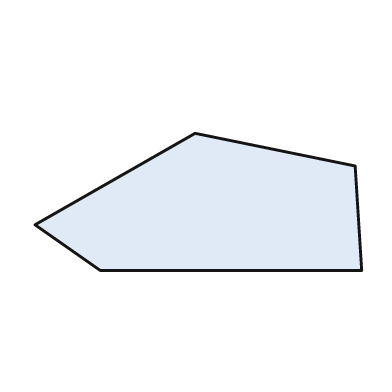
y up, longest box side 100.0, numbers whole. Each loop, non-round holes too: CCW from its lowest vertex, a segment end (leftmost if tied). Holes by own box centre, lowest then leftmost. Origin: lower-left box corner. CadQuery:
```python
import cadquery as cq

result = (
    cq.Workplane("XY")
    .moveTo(20.0, 0.0)
    .lineTo(100.0, 0.0)
    .lineTo(98.0, 32.0)
    .lineTo(49.0, 42.0)
    .lineTo(0.0, 14.0)
    .close()
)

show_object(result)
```